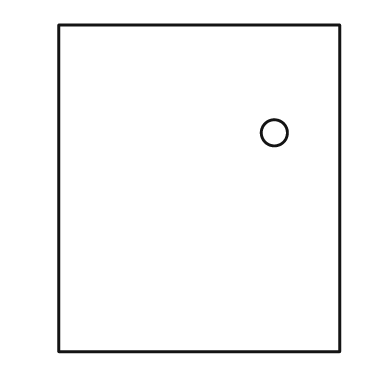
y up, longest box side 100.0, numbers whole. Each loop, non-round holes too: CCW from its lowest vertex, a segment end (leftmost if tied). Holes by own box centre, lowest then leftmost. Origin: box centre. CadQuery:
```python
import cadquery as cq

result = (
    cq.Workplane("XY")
    .moveTo(-43.0, -50.0)
    .lineTo(43.0, -50.0)
    .lineTo(43.0, 50.0)
    .lineTo(-43.0, 50.0)
    .close()
    .moveTo(23.0, 17.0)
    .circle(4.0)
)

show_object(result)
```